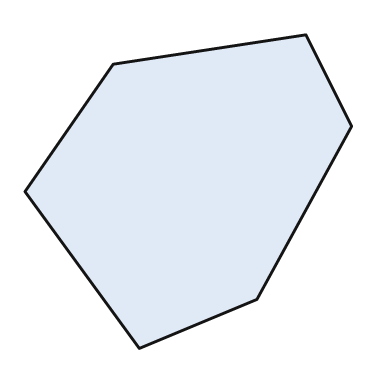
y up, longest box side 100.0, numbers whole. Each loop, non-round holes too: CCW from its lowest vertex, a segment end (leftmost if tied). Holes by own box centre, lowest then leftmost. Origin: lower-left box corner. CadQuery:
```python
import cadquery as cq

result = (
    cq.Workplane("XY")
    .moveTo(35.0, 0.0)
    .lineTo(71.0, 15.0)
    .lineTo(100.0, 68.0)
    .lineTo(86.0, 96.0)
    .lineTo(27.0, 87.0)
    .lineTo(0.0, 48.0)
    .close()
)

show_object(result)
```